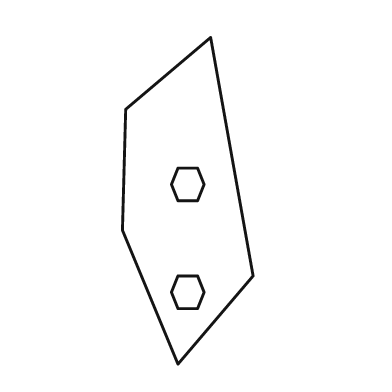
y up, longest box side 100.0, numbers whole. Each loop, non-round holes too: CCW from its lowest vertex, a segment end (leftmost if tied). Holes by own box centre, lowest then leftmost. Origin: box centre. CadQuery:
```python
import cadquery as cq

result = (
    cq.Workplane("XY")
    .moveTo(-3.0, -50.0)
    .lineTo(20.0, -23.0)
    .lineTo(7.0, 50.0)
    .lineTo(-19.0, 28.0)
    .lineTo(-20.0, -9.0)
    .close()
    .moveTo(-3.0, -33.0)
    .lineTo(3.0, -33.0)
    .lineTo(5.0, -28.0)
    .lineTo(3.0, -23.0)
    .lineTo(-3.0, -23.0)
    .lineTo(-5.0, -28.0)
    .close()
    .moveTo(-3.0, 0.0)
    .lineTo(3.0, 0.0)
    .lineTo(5.0, 5.0)
    .lineTo(3.0, 10.0)
    .lineTo(-3.0, 10.0)
    .lineTo(-5.0, 5.0)
    .close()
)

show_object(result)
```